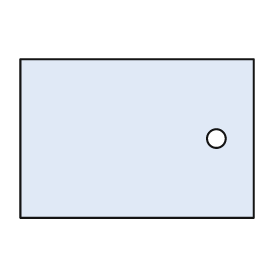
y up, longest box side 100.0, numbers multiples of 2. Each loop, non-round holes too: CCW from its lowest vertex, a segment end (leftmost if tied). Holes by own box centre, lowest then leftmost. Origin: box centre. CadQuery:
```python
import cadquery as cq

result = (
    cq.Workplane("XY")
    .moveTo(-50.0, -34.0)
    .lineTo(50.0, -34.0)
    .lineTo(50.0, 34.0)
    .lineTo(-50.0, 34.0)
    .close()
    .moveTo(34.0, 0.0)
    .circle(4.0)
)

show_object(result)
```